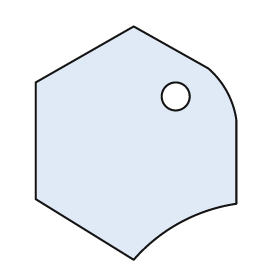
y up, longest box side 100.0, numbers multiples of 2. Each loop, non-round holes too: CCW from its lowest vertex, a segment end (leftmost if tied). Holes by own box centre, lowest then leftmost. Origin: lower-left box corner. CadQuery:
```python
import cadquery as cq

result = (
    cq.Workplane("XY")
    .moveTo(42.0, 0.0)
    .threePointArc((62.0, 16.0), (86.0, 24.0))
    .lineTo(86.0, 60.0)
    .threePointArc((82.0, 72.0), (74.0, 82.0))
    .lineTo(42.0, 100.0)
    .lineTo(0.0, 76.0)
    .lineTo(0.0, 26.0)
    .close()
    .moveTo(60.0, 70.0)
    .circle(6.0)
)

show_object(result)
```